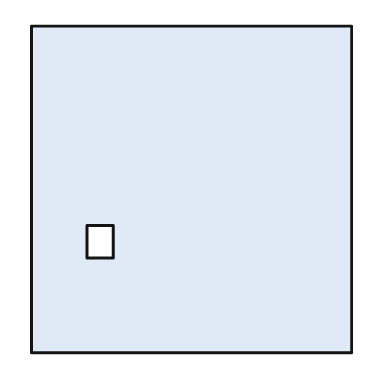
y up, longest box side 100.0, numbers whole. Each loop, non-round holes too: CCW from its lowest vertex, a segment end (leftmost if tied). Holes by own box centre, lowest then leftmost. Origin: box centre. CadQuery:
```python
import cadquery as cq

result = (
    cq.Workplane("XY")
    .moveTo(-49.0, -50.0)
    .lineTo(49.0, -50.0)
    .lineTo(49.0, 50.0)
    .lineTo(-49.0, 50.0)
    .close()
    .moveTo(-32.0, -21.0)
    .lineTo(-24.0, -21.0)
    .lineTo(-24.0, -11.0)
    .lineTo(-32.0, -11.0)
    .close()
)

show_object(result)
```